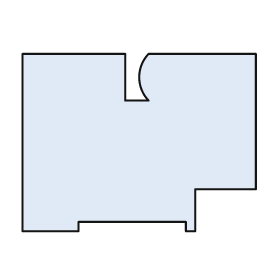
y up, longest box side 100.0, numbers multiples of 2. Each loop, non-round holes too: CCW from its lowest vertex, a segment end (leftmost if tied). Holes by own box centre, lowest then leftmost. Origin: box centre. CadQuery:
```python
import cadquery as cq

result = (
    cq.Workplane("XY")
    .moveTo(-50.0, -38.0)
    .lineTo(-26.0, -38.0)
    .lineTo(-26.0, -34.0)
    .lineTo(20.0, -34.0)
    .lineTo(20.0, -38.0)
    .lineTo(24.0, -38.0)
    .lineTo(24.0, -20.0)
    .lineTo(50.0, -20.0)
    .lineTo(50.0, 38.0)
    .lineTo(4.0, 38.0)
    .threePointArc((0.0, 28.0), (4.0, 18.0))
    .lineTo(-6.0, 18.0)
    .lineTo(-6.0, 38.0)
    .lineTo(-50.0, 38.0)
    .close()
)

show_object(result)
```